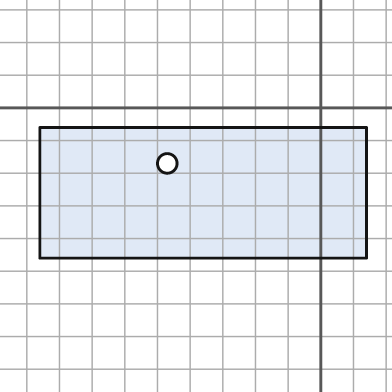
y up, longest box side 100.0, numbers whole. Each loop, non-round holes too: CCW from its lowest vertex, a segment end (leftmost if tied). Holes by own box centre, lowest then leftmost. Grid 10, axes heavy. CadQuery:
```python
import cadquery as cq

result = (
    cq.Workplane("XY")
    .moveTo(-86.0, -46.0)
    .lineTo(14.0, -46.0)
    .lineTo(14.0, -6.0)
    .lineTo(-86.0, -6.0)
    .close()
    .moveTo(-47.0, -17.0)
    .circle(3.0)
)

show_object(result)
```